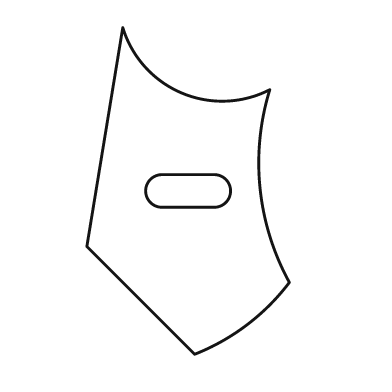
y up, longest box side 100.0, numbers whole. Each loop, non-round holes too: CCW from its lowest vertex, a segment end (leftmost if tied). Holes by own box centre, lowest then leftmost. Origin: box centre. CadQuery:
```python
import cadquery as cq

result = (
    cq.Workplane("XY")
    .moveTo(2.0, -50.0)
    .threePointArc((18.0, -41.0), (31.0, -28.0))
    .threePointArc((22.0, 1.0), (25.0, 31.0))
    .threePointArc((-2.0, 30.0), (-20.0, 50.0))
    .lineTo(-31.0, -17.0)
    .close()
    .moveTo(-8.0, -5.0)
    .lineTo(8.0, -5.0)
    .threePointArc((13.0, 0.0), (8.0, 5.0))
    .lineTo(-8.0, 5.0)
    .threePointArc((-13.0, 0.0), (-8.0, -5.0))
    .close()
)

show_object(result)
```